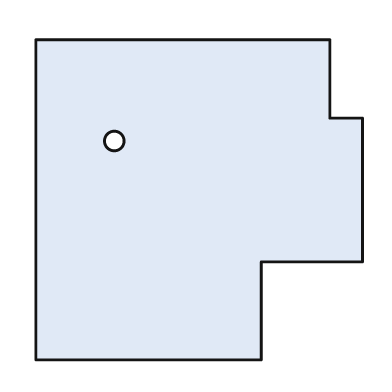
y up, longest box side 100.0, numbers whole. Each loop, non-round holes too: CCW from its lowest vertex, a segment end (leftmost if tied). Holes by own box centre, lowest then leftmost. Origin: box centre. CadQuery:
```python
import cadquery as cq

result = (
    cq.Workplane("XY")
    .moveTo(-50.0, -49.0)
    .lineTo(19.0, -49.0)
    .lineTo(19.0, -19.0)
    .lineTo(50.0, -19.0)
    .lineTo(50.0, 25.0)
    .lineTo(40.0, 25.0)
    .lineTo(40.0, 49.0)
    .lineTo(-50.0, 49.0)
    .close()
    .moveTo(-26.0, 18.0)
    .circle(3.0)
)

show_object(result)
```